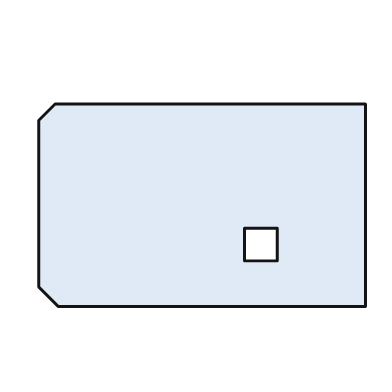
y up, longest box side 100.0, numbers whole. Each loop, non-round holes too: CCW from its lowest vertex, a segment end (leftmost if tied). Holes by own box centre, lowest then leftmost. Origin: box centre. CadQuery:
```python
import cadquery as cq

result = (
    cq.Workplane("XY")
    .moveTo(-44.0, -31.0)
    .lineTo(50.0, -31.0)
    .lineTo(50.0, 31.0)
    .lineTo(-45.0, 31.0)
    .lineTo(-50.0, 26.0)
    .lineTo(-50.0, -25.0)
    .close()
    .moveTo(13.0, -17.0)
    .lineTo(23.0, -17.0)
    .lineTo(23.0, -7.0)
    .lineTo(13.0, -7.0)
    .close()
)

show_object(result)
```